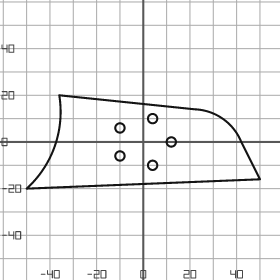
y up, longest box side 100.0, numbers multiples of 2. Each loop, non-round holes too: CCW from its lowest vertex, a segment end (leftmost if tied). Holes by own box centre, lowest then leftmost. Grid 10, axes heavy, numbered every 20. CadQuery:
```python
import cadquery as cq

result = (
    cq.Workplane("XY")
    .moveTo(-50.0, -20.0)
    .lineTo(50.0, -16.0)
    .lineTo(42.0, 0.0)
    .threePointArc((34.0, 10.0), (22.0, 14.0))
    .lineTo(-36.0, 20.0)
    .threePointArc((-38.0, -2.0), (-50.0, -20.0))
    .close()
    .moveTo(4.0, -10.0)
    .circle(2.0)
    .moveTo(-10.0, -6.0)
    .circle(2.0)
    .moveTo(12.0, 0.0)
    .circle(2.0)
    .moveTo(-10.0, 6.0)
    .circle(2.0)
    .moveTo(4.0, 10.0)
    .circle(2.0)
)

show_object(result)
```